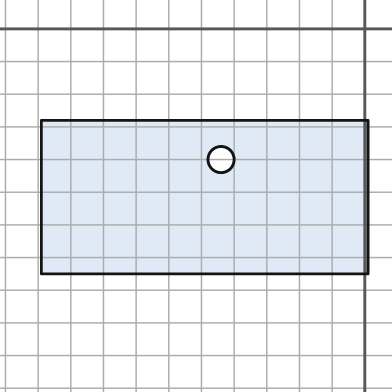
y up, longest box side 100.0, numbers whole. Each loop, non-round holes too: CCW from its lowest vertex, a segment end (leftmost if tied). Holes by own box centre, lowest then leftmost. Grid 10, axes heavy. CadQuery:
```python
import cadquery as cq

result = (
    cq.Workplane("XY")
    .moveTo(-99.0, -75.0)
    .lineTo(1.0, -75.0)
    .lineTo(1.0, -28.0)
    .lineTo(-99.0, -28.0)
    .close()
    .moveTo(-44.0, -40.0)
    .circle(4.0)
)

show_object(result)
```